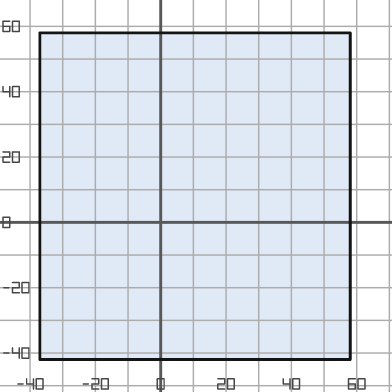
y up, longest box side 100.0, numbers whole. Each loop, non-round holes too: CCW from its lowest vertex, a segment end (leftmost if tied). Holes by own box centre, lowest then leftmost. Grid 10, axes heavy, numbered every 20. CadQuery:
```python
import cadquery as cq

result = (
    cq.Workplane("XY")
    .moveTo(-37.0, -42.0)
    .lineTo(58.0, -42.0)
    .lineTo(58.0, 58.0)
    .lineTo(-37.0, 58.0)
    .close()
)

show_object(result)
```